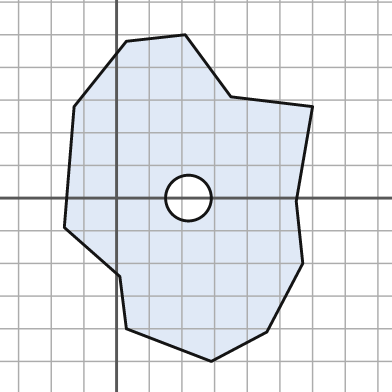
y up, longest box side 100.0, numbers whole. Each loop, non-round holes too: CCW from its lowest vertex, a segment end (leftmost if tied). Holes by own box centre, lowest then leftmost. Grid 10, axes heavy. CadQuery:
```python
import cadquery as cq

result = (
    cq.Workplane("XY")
    .moveTo(29.0, -50.0)
    .lineTo(46.0, -41.0)
    .lineTo(57.0, -20.0)
    .lineTo(55.0, -1.0)
    .lineTo(60.0, 28.0)
    .lineTo(35.0, 31.0)
    .lineTo(21.0, 50.0)
    .lineTo(3.0, 48.0)
    .lineTo(-13.0, 28.0)
    .lineTo(-16.0, -9.0)
    .lineTo(1.0, -24.0)
    .lineTo(3.0, -40.0)
    .close()
    .moveTo(22.0, 0.0)
    .circle(7.0)
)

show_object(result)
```